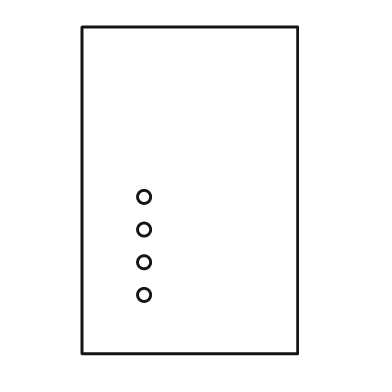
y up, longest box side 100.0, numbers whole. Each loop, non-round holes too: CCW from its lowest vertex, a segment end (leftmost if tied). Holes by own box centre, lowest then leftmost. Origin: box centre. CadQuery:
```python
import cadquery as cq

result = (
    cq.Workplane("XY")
    .moveTo(-33.0, -50.0)
    .lineTo(33.0, -50.0)
    .lineTo(33.0, 50.0)
    .lineTo(-33.0, 50.0)
    .close()
    .moveTo(-14.0, -32.0)
    .circle(2.0)
    .moveTo(-14.0, -22.0)
    .circle(2.0)
    .moveTo(-14.0, -12.0)
    .circle(2.0)
    .moveTo(-14.0, -2.0)
    .circle(2.0)
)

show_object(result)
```